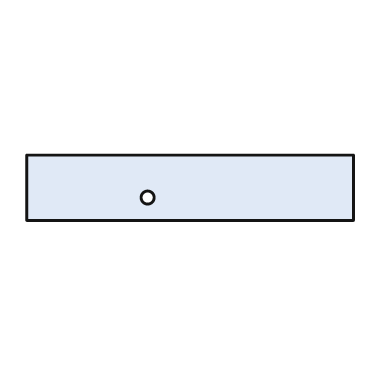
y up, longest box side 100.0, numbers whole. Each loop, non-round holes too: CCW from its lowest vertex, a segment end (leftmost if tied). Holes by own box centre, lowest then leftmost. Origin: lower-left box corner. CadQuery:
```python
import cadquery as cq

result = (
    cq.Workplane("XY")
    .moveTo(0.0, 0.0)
    .lineTo(100.0, 0.0)
    .lineTo(100.0, 20.0)
    .lineTo(0.0, 20.0)
    .close()
    .moveTo(37.0, 7.0)
    .circle(2.0)
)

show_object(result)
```